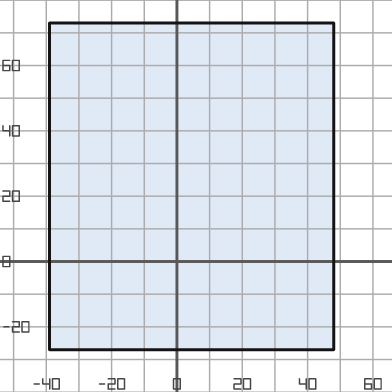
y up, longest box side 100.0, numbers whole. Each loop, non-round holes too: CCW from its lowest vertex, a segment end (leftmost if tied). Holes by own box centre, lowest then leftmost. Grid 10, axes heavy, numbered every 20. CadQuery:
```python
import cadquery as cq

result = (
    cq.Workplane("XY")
    .moveTo(-39.0, -27.0)
    .lineTo(48.0, -27.0)
    .lineTo(48.0, 73.0)
    .lineTo(-39.0, 73.0)
    .close()
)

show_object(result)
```